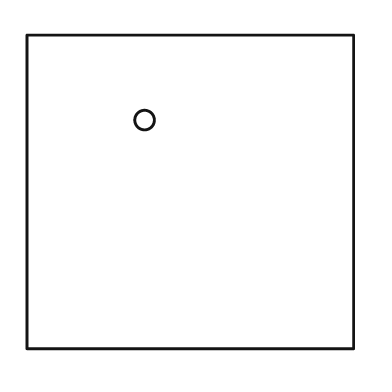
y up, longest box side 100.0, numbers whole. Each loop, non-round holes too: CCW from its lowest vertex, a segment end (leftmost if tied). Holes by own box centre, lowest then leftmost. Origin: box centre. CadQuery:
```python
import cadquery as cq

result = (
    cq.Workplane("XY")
    .moveTo(-50.0, -48.0)
    .lineTo(50.0, -48.0)
    .lineTo(50.0, 48.0)
    .lineTo(-50.0, 48.0)
    .close()
    .moveTo(-14.0, 22.0)
    .circle(3.0)
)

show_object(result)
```